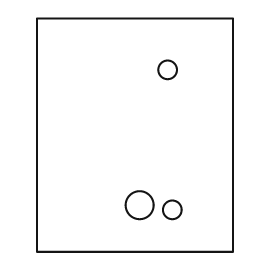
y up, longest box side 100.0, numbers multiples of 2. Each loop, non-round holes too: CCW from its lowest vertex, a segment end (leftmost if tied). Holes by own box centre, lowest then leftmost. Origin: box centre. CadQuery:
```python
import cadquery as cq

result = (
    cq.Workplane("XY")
    .moveTo(-42.0, -50.0)
    .lineTo(42.0, -50.0)
    .lineTo(42.0, 50.0)
    .lineTo(-42.0, 50.0)
    .close()
    .moveTo(16.0, -32.0)
    .circle(4.0)
    .moveTo(2.0, -30.0)
    .circle(6.0)
    .moveTo(14.0, 28.0)
    .circle(4.0)
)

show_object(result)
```